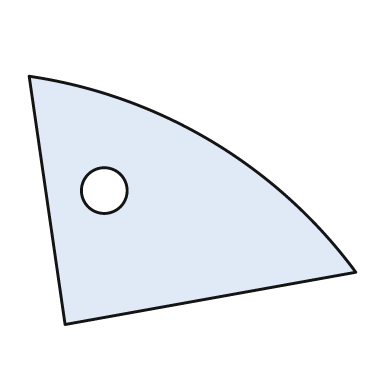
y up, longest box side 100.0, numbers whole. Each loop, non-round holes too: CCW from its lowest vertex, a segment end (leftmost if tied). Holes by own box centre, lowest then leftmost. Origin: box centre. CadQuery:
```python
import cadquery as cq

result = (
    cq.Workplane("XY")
    .moveTo(-39.0, -38.0)
    .lineTo(50.0, -22.0)
    .threePointArc((6.0, 18.0), (-50.0, 38.0))
    .close()
    .moveTo(-27.0, 3.0)
    .circle(7.0)
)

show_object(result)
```